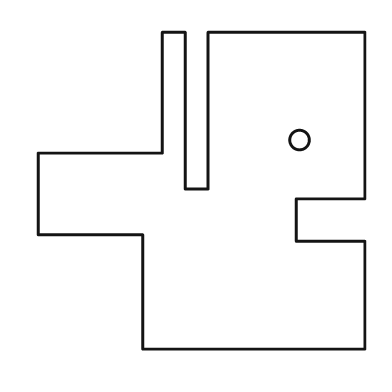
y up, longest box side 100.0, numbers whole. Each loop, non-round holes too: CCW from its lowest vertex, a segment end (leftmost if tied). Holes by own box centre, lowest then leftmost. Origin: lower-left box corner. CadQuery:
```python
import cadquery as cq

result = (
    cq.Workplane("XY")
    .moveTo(32.0, 0.0)
    .lineTo(100.0, 0.0)
    .lineTo(100.0, 33.0)
    .lineTo(79.0, 33.0)
    .lineTo(79.0, 46.0)
    .lineTo(100.0, 46.0)
    .lineTo(100.0, 97.0)
    .lineTo(52.0, 97.0)
    .lineTo(52.0, 49.0)
    .lineTo(45.0, 49.0)
    .lineTo(45.0, 97.0)
    .lineTo(38.0, 97.0)
    .lineTo(38.0, 60.0)
    .lineTo(0.0, 60.0)
    .lineTo(0.0, 35.0)
    .lineTo(32.0, 35.0)
    .close()
    .moveTo(80.0, 64.0)
    .circle(3.0)
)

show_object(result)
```